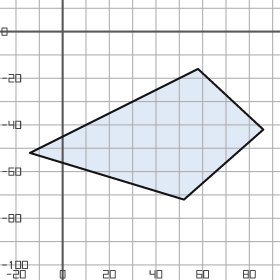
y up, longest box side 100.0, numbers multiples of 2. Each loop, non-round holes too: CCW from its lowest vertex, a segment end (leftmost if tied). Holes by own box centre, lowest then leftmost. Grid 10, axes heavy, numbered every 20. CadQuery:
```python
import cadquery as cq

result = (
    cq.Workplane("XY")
    .moveTo(52.0, -72.0)
    .lineTo(86.0, -42.0)
    .lineTo(58.0, -16.0)
    .lineTo(-14.0, -52.0)
    .close()
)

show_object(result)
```